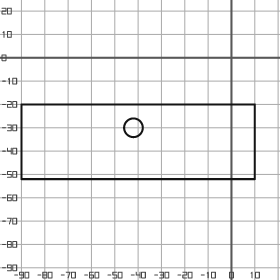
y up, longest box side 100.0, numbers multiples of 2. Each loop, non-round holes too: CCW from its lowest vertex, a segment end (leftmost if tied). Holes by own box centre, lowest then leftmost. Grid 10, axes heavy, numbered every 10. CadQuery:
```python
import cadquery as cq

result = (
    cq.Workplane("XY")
    .moveTo(-90.0, -52.0)
    .lineTo(10.0, -52.0)
    .lineTo(10.0, -20.0)
    .lineTo(-90.0, -20.0)
    .close()
    .moveTo(-42.0, -30.0)
    .circle(4.0)
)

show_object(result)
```